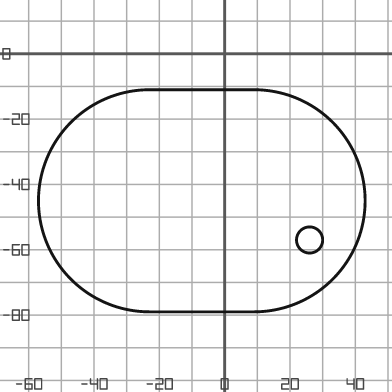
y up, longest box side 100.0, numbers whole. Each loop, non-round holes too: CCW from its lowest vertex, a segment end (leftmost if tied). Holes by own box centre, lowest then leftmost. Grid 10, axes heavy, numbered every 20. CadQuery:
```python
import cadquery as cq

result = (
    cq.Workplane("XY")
    .moveTo(-23.0, -79.0)
    .lineTo(9.0, -79.0)
    .threePointArc((43.0, -45.0), (9.0, -11.0))
    .lineTo(-23.0, -11.0)
    .threePointArc((-57.0, -45.0), (-23.0, -79.0))
    .close()
    .moveTo(26.0, -57.0)
    .circle(4.0)
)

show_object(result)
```